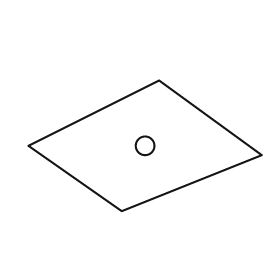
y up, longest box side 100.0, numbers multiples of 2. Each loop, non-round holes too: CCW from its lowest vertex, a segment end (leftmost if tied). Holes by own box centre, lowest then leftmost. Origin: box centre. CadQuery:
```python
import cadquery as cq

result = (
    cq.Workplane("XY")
    .moveTo(-10.0, -28.0)
    .lineTo(50.0, -4.0)
    .lineTo(6.0, 28.0)
    .lineTo(-50.0, 0.0)
    .close()
    .moveTo(0.0, 0.0)
    .circle(4.0)
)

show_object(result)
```